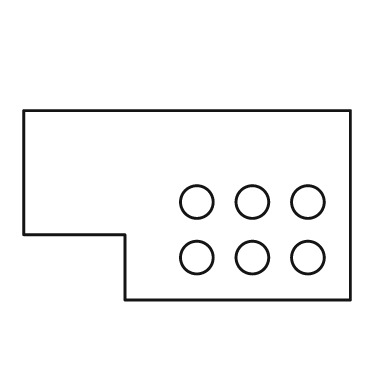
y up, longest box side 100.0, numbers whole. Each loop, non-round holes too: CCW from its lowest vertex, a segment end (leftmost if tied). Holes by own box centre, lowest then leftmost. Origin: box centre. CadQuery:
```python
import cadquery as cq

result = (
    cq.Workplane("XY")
    .moveTo(-19.0, -29.0)
    .lineTo(50.0, -29.0)
    .lineTo(50.0, 29.0)
    .lineTo(-50.0, 29.0)
    .lineTo(-50.0, -9.0)
    .lineTo(-19.0, -9.0)
    .close()
    .moveTo(3.0, -16.0)
    .circle(5.0)
    .moveTo(20.0, -16.0)
    .circle(5.0)
    .moveTo(37.0, -16.0)
    .circle(5.0)
    .moveTo(3.0, 1.0)
    .circle(5.0)
    .moveTo(20.0, 1.0)
    .circle(5.0)
    .moveTo(37.0, 1.0)
    .circle(5.0)
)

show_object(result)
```